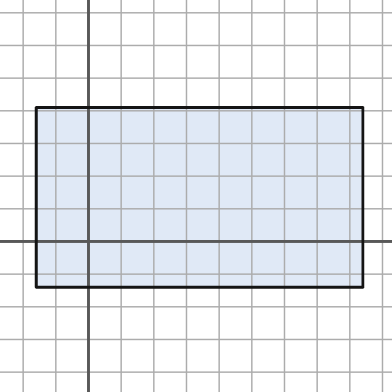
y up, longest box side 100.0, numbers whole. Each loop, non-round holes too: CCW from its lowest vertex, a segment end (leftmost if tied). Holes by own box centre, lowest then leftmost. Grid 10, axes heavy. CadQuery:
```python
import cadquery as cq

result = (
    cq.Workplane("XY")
    .moveTo(-16.0, -14.0)
    .lineTo(84.0, -14.0)
    .lineTo(84.0, 41.0)
    .lineTo(-16.0, 41.0)
    .close()
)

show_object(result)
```